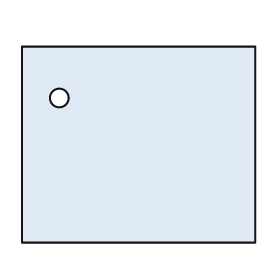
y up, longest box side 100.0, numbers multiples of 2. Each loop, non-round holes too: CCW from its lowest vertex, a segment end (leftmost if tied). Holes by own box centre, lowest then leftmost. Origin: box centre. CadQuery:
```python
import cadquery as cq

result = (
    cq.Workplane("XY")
    .moveTo(-50.0, -42.0)
    .lineTo(50.0, -42.0)
    .lineTo(50.0, 42.0)
    .lineTo(-50.0, 42.0)
    .close()
    .moveTo(-34.0, 20.0)
    .circle(4.0)
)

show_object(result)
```